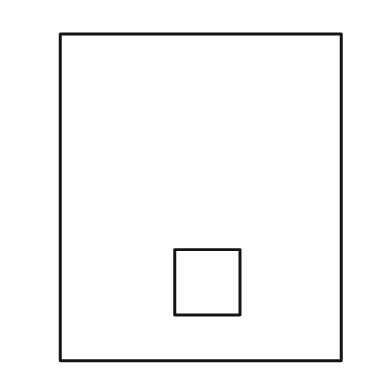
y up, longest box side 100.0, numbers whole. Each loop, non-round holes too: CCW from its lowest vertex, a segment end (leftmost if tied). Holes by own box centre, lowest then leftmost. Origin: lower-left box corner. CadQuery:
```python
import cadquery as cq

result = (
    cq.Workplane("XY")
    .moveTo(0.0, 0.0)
    .lineTo(86.0, 0.0)
    .lineTo(86.0, 100.0)
    .lineTo(0.0, 100.0)
    .close()
    .moveTo(35.0, 14.0)
    .lineTo(55.0, 14.0)
    .lineTo(55.0, 34.0)
    .lineTo(35.0, 34.0)
    .close()
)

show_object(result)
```